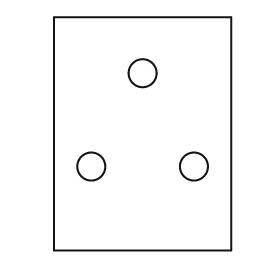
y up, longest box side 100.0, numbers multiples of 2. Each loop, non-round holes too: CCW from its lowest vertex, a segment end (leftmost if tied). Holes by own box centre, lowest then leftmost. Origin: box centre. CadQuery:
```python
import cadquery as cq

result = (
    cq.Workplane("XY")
    .moveTo(-38.0, -50.0)
    .lineTo(38.0, -50.0)
    .lineTo(38.0, 50.0)
    .lineTo(-38.0, 50.0)
    .close()
    .moveTo(-22.0, -14.0)
    .circle(6.0)
    .moveTo(22.0, -14.0)
    .circle(6.0)
    .moveTo(0.0, 26.0)
    .circle(6.0)
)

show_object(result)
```